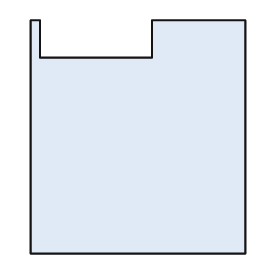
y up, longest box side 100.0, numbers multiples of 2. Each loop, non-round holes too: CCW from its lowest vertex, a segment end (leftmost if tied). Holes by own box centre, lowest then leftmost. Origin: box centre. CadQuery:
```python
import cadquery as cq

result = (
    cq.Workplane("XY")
    .moveTo(-46.0, -50.0)
    .lineTo(46.0, -50.0)
    .lineTo(46.0, 50.0)
    .lineTo(6.0, 50.0)
    .lineTo(6.0, 34.0)
    .lineTo(-42.0, 34.0)
    .lineTo(-42.0, 50.0)
    .lineTo(-46.0, 50.0)
    .close()
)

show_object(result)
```